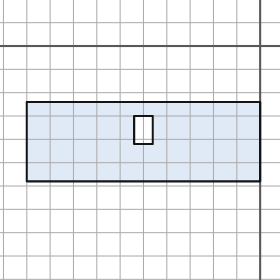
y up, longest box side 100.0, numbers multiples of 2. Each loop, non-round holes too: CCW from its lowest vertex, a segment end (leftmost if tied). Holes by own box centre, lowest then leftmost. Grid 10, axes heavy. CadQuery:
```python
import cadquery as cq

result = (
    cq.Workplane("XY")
    .moveTo(-100.0, -58.0)
    .lineTo(0.0, -58.0)
    .lineTo(0.0, -24.0)
    .lineTo(-100.0, -24.0)
    .close()
    .moveTo(-54.0, -42.0)
    .lineTo(-46.0, -42.0)
    .lineTo(-46.0, -30.0)
    .lineTo(-54.0, -30.0)
    .close()
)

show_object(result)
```